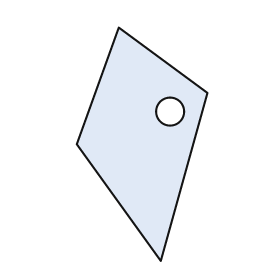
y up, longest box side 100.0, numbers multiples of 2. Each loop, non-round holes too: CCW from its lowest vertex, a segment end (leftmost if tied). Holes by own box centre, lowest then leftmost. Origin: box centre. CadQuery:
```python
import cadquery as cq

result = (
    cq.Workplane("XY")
    .moveTo(8.0, -50.0)
    .lineTo(28.0, 22.0)
    .lineTo(-10.0, 50.0)
    .lineTo(-28.0, 0.0)
    .close()
    .moveTo(12.0, 14.0)
    .circle(6.0)
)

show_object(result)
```